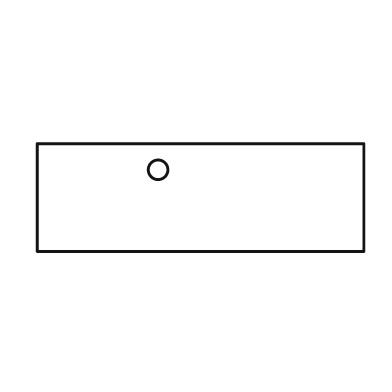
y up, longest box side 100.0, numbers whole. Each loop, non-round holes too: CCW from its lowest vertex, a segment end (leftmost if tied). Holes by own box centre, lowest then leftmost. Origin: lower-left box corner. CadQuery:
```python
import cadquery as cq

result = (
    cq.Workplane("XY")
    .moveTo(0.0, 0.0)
    .lineTo(100.0, 0.0)
    .lineTo(100.0, 33.0)
    .lineTo(0.0, 33.0)
    .close()
    .moveTo(37.0, 25.0)
    .circle(3.0)
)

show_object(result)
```